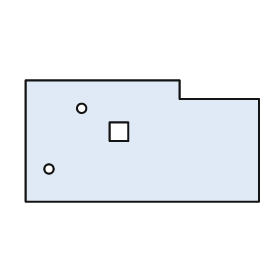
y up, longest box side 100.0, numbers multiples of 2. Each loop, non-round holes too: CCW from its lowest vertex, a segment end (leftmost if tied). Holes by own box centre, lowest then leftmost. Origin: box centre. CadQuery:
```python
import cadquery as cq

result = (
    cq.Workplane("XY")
    .moveTo(-50.0, -26.0)
    .lineTo(50.0, -26.0)
    .lineTo(50.0, 18.0)
    .lineTo(16.0, 18.0)
    .lineTo(16.0, 26.0)
    .lineTo(-50.0, 26.0)
    .close()
    .moveTo(-40.0, -12.0)
    .circle(2.0)
    .moveTo(-14.0, 0.0)
    .lineTo(-6.0, 0.0)
    .lineTo(-6.0, 8.0)
    .lineTo(-14.0, 8.0)
    .close()
    .moveTo(-26.0, 14.0)
    .circle(2.0)
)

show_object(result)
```